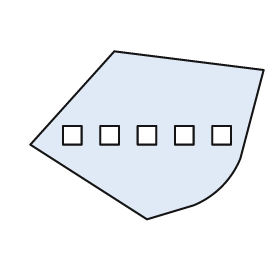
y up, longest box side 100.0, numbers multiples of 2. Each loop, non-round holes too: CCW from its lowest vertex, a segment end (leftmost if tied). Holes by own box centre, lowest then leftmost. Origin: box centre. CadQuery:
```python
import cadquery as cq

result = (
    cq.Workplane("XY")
    .moveTo(0.0, -36.0)
    .lineTo(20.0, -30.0)
    .threePointArc((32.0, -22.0), (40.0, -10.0))
    .lineTo(50.0, 28.0)
    .lineTo(-14.0, 36.0)
    .lineTo(-50.0, -4.0)
    .close()
    .moveTo(-36.0, -4.0)
    .lineTo(-28.0, -4.0)
    .lineTo(-28.0, 4.0)
    .lineTo(-36.0, 4.0)
    .close()
    .moveTo(-20.0, -4.0)
    .lineTo(-12.0, -4.0)
    .lineTo(-12.0, 4.0)
    .lineTo(-20.0, 4.0)
    .close()
    .moveTo(-4.0, -4.0)
    .lineTo(4.0, -4.0)
    .lineTo(4.0, 4.0)
    .lineTo(-4.0, 4.0)
    .close()
    .moveTo(12.0, -4.0)
    .lineTo(20.0, -4.0)
    .lineTo(20.0, 4.0)
    .lineTo(12.0, 4.0)
    .close()
    .moveTo(28.0, -4.0)
    .lineTo(36.0, -4.0)
    .lineTo(36.0, 4.0)
    .lineTo(28.0, 4.0)
    .close()
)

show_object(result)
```